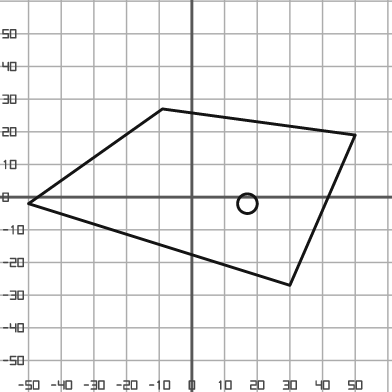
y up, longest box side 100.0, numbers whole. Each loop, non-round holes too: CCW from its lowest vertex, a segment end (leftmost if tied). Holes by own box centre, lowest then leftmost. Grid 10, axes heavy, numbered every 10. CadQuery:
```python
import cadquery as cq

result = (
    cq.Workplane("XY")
    .moveTo(30.0, -27.0)
    .lineTo(50.0, 19.0)
    .lineTo(-9.0, 27.0)
    .lineTo(-50.0, -2.0)
    .close()
    .moveTo(17.0, -2.0)
    .circle(3.0)
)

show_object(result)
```